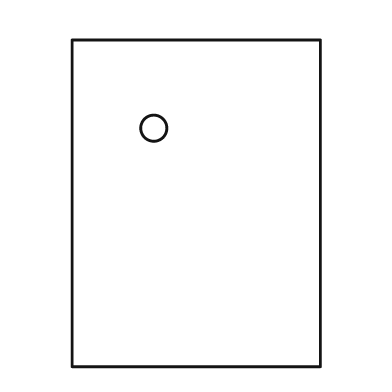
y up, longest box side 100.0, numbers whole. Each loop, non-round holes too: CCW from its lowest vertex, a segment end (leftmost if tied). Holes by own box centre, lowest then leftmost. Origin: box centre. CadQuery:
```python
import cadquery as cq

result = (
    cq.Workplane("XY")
    .moveTo(-38.0, -50.0)
    .lineTo(38.0, -50.0)
    .lineTo(38.0, 50.0)
    .lineTo(-38.0, 50.0)
    .close()
    .moveTo(-13.0, 23.0)
    .circle(4.0)
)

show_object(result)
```